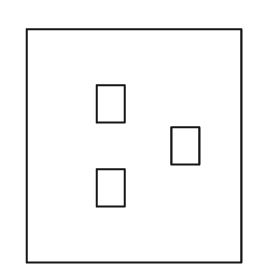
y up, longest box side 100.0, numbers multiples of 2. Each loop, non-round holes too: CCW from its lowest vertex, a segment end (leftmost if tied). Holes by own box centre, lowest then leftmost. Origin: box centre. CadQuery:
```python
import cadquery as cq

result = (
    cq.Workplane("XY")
    .moveTo(-46.0, -50.0)
    .lineTo(46.0, -50.0)
    .lineTo(46.0, 50.0)
    .lineTo(-46.0, 50.0)
    .close()
    .moveTo(-16.0, -26.0)
    .lineTo(-4.0, -26.0)
    .lineTo(-4.0, -10.0)
    .lineTo(-16.0, -10.0)
    .close()
    .moveTo(16.0, -8.0)
    .lineTo(28.0, -8.0)
    .lineTo(28.0, 8.0)
    .lineTo(16.0, 8.0)
    .close()
    .moveTo(-16.0, 10.0)
    .lineTo(-4.0, 10.0)
    .lineTo(-4.0, 26.0)
    .lineTo(-16.0, 26.0)
    .close()
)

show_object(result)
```